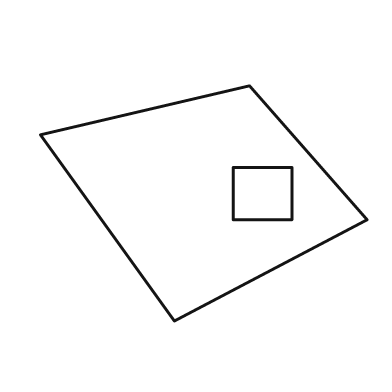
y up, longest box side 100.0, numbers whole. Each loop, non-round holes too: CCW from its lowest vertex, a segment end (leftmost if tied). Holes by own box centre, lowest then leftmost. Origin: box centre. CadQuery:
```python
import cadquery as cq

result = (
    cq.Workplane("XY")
    .moveTo(-9.0, -36.0)
    .lineTo(50.0, -5.0)
    .lineTo(14.0, 36.0)
    .lineTo(-50.0, 21.0)
    .close()
    .moveTo(9.0, -5.0)
    .lineTo(27.0, -5.0)
    .lineTo(27.0, 11.0)
    .lineTo(9.0, 11.0)
    .close()
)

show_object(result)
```